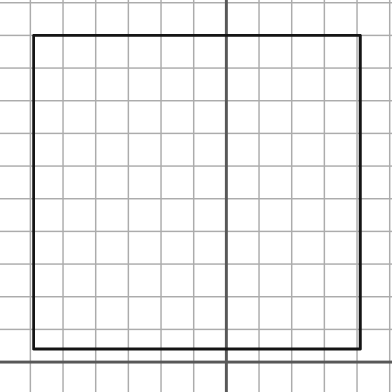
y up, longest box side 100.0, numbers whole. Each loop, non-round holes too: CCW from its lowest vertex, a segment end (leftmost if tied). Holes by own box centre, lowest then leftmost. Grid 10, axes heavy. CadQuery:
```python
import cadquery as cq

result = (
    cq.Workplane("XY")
    .moveTo(-59.0, 4.0)
    .lineTo(41.0, 4.0)
    .lineTo(41.0, 100.0)
    .lineTo(-59.0, 100.0)
    .close()
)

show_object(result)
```